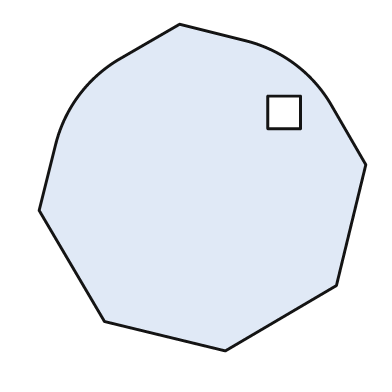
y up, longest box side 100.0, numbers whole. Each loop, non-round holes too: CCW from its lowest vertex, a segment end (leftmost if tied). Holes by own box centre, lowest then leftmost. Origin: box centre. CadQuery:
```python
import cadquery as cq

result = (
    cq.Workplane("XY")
    .moveTo(7.0, -50.0)
    .lineTo(41.0, -30.0)
    .lineTo(50.0, 7.0)
    .lineTo(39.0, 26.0)
    .threePointArc((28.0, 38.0), (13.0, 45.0))
    .lineTo(-7.0, 50.0)
    .lineTo(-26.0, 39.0)
    .threePointArc((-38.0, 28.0), (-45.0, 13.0))
    .lineTo(-50.0, -7.0)
    .lineTo(-30.0, -41.0)
    .close()
    .moveTo(20.0, 18.0)
    .lineTo(30.0, 18.0)
    .lineTo(30.0, 28.0)
    .lineTo(20.0, 28.0)
    .close()
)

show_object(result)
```